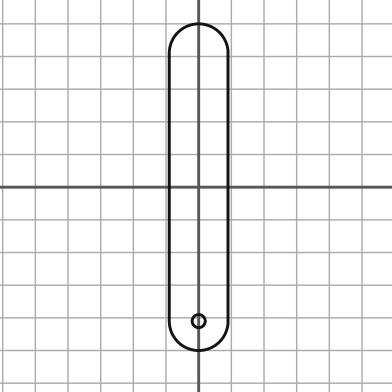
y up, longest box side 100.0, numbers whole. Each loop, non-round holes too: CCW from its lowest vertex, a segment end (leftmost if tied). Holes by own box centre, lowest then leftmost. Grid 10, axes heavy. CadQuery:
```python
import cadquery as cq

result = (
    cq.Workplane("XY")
    .moveTo(-9.0, -41.0)
    .threePointArc((0.0, -50.0), (9.0, -41.0))
    .lineTo(9.0, 41.0)
    .threePointArc((0.0, 50.0), (-9.0, 41.0))
    .close()
    .moveTo(0.0, -41.0)
    .circle(2.0)
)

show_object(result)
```